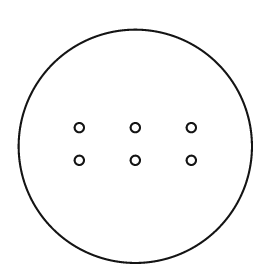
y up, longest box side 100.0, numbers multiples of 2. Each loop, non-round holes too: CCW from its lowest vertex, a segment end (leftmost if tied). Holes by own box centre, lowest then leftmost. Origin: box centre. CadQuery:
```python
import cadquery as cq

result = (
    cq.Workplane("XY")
    .moveTo(0.0, 0.0)
    .circle(50.0)
    .moveTo(-24.0, -6.0)
    .circle(2.0)
    .moveTo(0.0, -6.0)
    .circle(2.0)
    .moveTo(24.0, -6.0)
    .circle(2.0)
    .moveTo(-24.0, 8.0)
    .circle(2.0)
    .moveTo(0.0, 8.0)
    .circle(2.0)
    .moveTo(24.0, 8.0)
    .circle(2.0)
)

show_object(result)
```